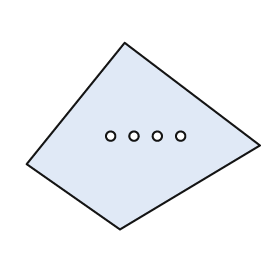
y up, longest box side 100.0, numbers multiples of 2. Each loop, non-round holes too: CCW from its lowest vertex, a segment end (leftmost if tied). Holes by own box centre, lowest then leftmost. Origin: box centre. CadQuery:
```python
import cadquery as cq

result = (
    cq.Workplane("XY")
    .moveTo(-10.0, -40.0)
    .lineTo(50.0, -4.0)
    .lineTo(-8.0, 40.0)
    .lineTo(-50.0, -12.0)
    .close()
    .moveTo(-14.0, 0.0)
    .circle(2.0)
    .moveTo(-4.0, 0.0)
    .circle(2.0)
    .moveTo(6.0, 0.0)
    .circle(2.0)
    .moveTo(16.0, 0.0)
    .circle(2.0)
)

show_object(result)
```